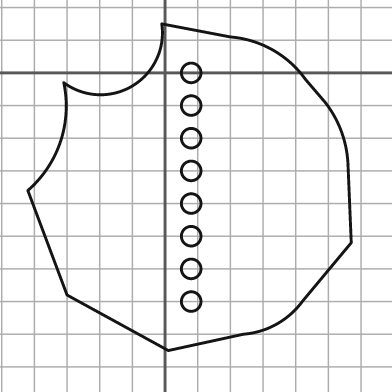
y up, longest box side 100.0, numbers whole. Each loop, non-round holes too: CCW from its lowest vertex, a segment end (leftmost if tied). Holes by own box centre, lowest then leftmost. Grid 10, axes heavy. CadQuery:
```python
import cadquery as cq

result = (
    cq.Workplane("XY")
    .moveTo(1.0, -85.0)
    .lineTo(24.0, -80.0)
    .threePointArc((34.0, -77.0), (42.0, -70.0))
    .lineTo(57.0, -52.0)
    .lineTo(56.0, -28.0)
    .threePointArc((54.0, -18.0), (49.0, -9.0))
    .lineTo(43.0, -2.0)
    .threePointArc((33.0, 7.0), (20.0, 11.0))
    .lineTo(-1.0, 15.0)
    .threePointArc((-10.0, -4.0), (-31.0, -3.0))
    .threePointArc((-32.0, -21.0), (-42.0, -36.0))
    .lineTo(-30.0, -68.0)
    .close()
    .moveTo(8.0, -70.0)
    .circle(3.0)
    .moveTo(8.0, -60.0)
    .circle(3.0)
    .moveTo(8.0, -50.0)
    .circle(3.0)
    .moveTo(8.0, -40.0)
    .circle(3.0)
    .moveTo(8.0, -30.0)
    .circle(3.0)
    .moveTo(8.0, -20.0)
    .circle(3.0)
    .moveTo(8.0, -10.0)
    .circle(3.0)
    .moveTo(8.0, 0.0)
    .circle(3.0)
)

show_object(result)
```